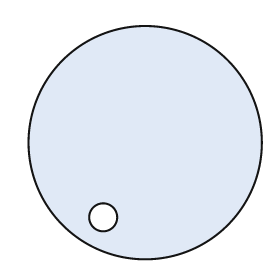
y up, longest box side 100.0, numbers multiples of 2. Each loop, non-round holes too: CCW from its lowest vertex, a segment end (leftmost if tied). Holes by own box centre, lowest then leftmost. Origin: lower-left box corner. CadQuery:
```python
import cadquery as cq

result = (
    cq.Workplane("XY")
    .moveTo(50.0, 50.0)
    .circle(50.0)
    .moveTo(32.0, 18.0)
    .circle(6.0)
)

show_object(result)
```